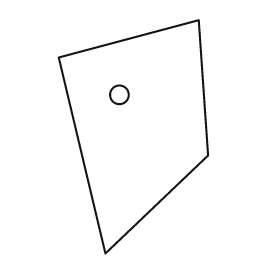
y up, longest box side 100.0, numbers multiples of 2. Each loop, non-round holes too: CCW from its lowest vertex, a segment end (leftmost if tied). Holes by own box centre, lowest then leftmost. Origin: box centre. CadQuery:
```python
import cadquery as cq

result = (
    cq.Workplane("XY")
    .moveTo(-12.0, -50.0)
    .lineTo(32.0, -8.0)
    .lineTo(28.0, 50.0)
    .lineTo(-32.0, 34.0)
    .close()
    .moveTo(-6.0, 18.0)
    .circle(4.0)
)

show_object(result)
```